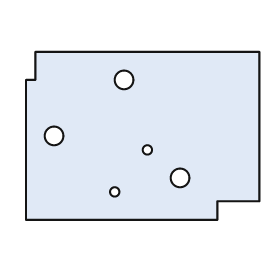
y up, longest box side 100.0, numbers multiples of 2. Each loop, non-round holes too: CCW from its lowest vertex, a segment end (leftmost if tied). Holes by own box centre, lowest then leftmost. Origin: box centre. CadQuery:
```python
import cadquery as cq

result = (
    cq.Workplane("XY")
    .moveTo(-50.0, -36.0)
    .lineTo(32.0, -36.0)
    .lineTo(32.0, -28.0)
    .lineTo(50.0, -28.0)
    .lineTo(50.0, 36.0)
    .lineTo(-46.0, 36.0)
    .lineTo(-46.0, 24.0)
    .lineTo(-50.0, 24.0)
    .close()
    .moveTo(-12.0, -24.0)
    .circle(2.0)
    .moveTo(16.0, -18.0)
    .circle(4.0)
    .moveTo(2.0, -6.0)
    .circle(2.0)
    .moveTo(-38.0, 0.0)
    .circle(4.0)
    .moveTo(-8.0, 24.0)
    .circle(4.0)
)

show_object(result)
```